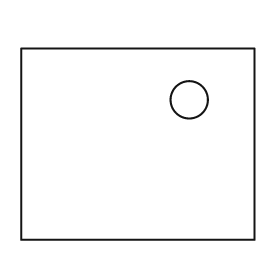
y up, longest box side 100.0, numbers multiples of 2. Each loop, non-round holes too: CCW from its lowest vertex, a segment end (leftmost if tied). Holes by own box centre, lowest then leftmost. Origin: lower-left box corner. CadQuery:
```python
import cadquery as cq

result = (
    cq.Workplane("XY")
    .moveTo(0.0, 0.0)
    .lineTo(100.0, 0.0)
    .lineTo(100.0, 82.0)
    .lineTo(0.0, 82.0)
    .close()
    .moveTo(72.0, 60.0)
    .circle(8.0)
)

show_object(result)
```